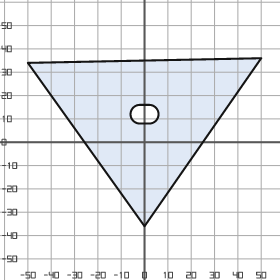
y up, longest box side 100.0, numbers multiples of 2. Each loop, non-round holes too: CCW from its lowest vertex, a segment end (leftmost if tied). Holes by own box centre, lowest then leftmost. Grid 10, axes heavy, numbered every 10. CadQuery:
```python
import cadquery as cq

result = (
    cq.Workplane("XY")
    .moveTo(0.0, -36.0)
    .lineTo(50.0, 36.0)
    .lineTo(-50.0, 34.0)
    .close()
    .moveTo(-2.0, 8.0)
    .lineTo(2.0, 8.0)
    .threePointArc((6.0, 12.0), (2.0, 16.0))
    .lineTo(-2.0, 16.0)
    .threePointArc((-6.0, 12.0), (-2.0, 8.0))
    .close()
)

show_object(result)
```